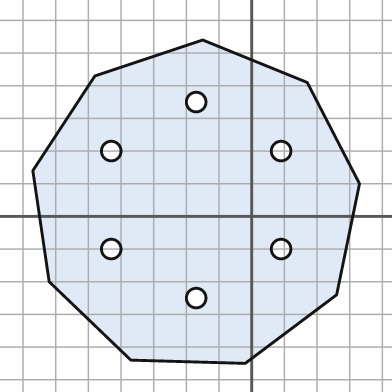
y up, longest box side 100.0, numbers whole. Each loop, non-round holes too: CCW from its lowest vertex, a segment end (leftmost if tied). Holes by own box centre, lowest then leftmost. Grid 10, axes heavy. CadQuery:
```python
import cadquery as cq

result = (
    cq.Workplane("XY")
    .moveTo(-2.0, -45.0)
    .lineTo(26.0, -24.0)
    .lineTo(33.0, 10.0)
    .lineTo(17.0, 41.0)
    .lineTo(-15.0, 54.0)
    .lineTo(-48.0, 43.0)
    .lineTo(-67.0, 14.0)
    .lineTo(-62.0, -20.0)
    .lineTo(-37.0, -44.0)
    .close()
    .moveTo(-17.0, -25.0)
    .circle(3.0)
    .moveTo(-43.0, -10.0)
    .circle(3.0)
    .moveTo(9.0, -10.0)
    .circle(3.0)
    .moveTo(-43.0, 20.0)
    .circle(3.0)
    .moveTo(9.0, 20.0)
    .circle(3.0)
    .moveTo(-17.0, 35.0)
    .circle(3.0)
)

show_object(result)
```